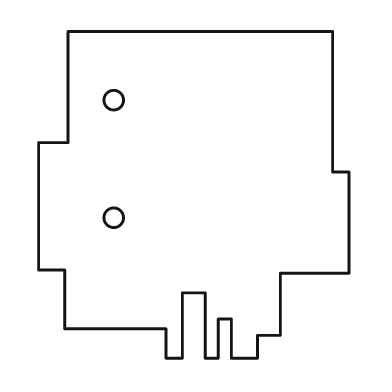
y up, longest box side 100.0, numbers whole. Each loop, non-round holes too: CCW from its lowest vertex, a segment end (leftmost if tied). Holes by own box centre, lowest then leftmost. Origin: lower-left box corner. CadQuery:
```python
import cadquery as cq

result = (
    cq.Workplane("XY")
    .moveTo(39.0, 0.0)
    .lineTo(44.0, 0.0)
    .lineTo(44.0, 20.0)
    .lineTo(51.0, 20.0)
    .lineTo(51.0, 0.0)
    .lineTo(55.0, 0.0)
    .lineTo(55.0, 12.0)
    .lineTo(59.0, 12.0)
    .lineTo(59.0, 0.0)
    .lineTo(67.0, 0.0)
    .lineTo(67.0, 7.0)
    .lineTo(74.0, 7.0)
    .lineTo(74.0, 26.0)
    .lineTo(95.0, 26.0)
    .lineTo(95.0, 57.0)
    .lineTo(90.0, 57.0)
    .lineTo(90.0, 100.0)
    .lineTo(9.0, 100.0)
    .lineTo(9.0, 66.0)
    .lineTo(0.0, 66.0)
    .lineTo(0.0, 27.0)
    .lineTo(8.0, 27.0)
    .lineTo(8.0, 9.0)
    .lineTo(39.0, 9.0)
    .close()
    .moveTo(23.0, 43.0)
    .circle(3.0)
    .moveTo(23.0, 79.0)
    .circle(3.0)
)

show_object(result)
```